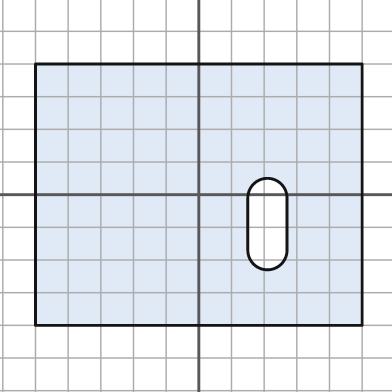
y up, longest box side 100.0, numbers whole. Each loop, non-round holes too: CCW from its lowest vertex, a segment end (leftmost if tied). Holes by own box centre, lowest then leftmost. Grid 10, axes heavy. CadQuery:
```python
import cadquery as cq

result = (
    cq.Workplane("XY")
    .moveTo(-50.0, -40.0)
    .lineTo(50.0, -40.0)
    .lineTo(50.0, 40.0)
    .lineTo(-50.0, 40.0)
    .close()
    .moveTo(15.0, -17.0)
    .threePointArc((21.0, -23.0), (27.0, -17.0))
    .lineTo(27.0, -1.0)
    .threePointArc((21.0, 5.0), (15.0, -1.0))
    .close()
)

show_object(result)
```